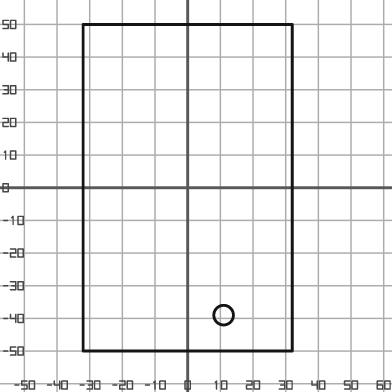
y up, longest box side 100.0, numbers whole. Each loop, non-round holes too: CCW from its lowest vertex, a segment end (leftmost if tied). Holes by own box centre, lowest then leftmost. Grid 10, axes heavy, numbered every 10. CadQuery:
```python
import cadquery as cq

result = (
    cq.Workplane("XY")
    .moveTo(-32.0, -50.0)
    .lineTo(32.0, -50.0)
    .lineTo(32.0, 50.0)
    .lineTo(-32.0, 50.0)
    .close()
    .moveTo(11.0, -39.0)
    .circle(3.0)
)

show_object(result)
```